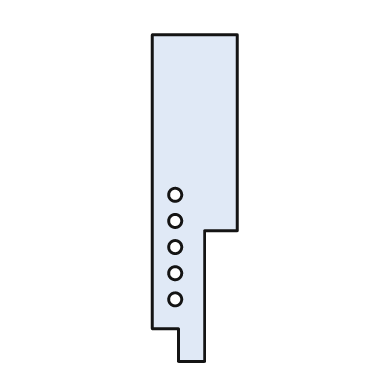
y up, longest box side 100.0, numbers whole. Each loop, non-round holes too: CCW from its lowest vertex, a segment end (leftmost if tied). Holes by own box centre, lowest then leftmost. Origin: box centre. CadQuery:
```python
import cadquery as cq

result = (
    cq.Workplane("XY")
    .moveTo(-5.0, -50.0)
    .lineTo(3.0, -50.0)
    .lineTo(3.0, -10.0)
    .lineTo(13.0, -10.0)
    .lineTo(13.0, 50.0)
    .lineTo(-13.0, 50.0)
    .lineTo(-13.0, -40.0)
    .lineTo(-5.0, -40.0)
    .close()
    .moveTo(-6.0, -31.0)
    .circle(2.0)
    .moveTo(-6.0, -23.0)
    .circle(2.0)
    .moveTo(-6.0, -15.0)
    .circle(2.0)
    .moveTo(-6.0, -7.0)
    .circle(2.0)
    .moveTo(-6.0, 1.0)
    .circle(2.0)
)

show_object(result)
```